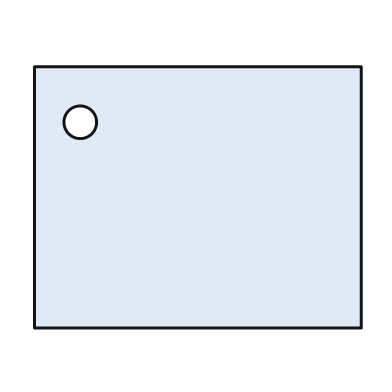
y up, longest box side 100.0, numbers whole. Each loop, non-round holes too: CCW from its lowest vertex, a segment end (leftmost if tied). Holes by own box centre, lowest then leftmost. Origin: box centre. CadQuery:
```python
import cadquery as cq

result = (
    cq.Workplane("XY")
    .moveTo(-50.0, -40.0)
    .lineTo(50.0, -40.0)
    .lineTo(50.0, 40.0)
    .lineTo(-50.0, 40.0)
    .close()
    .moveTo(-36.0, 23.0)
    .circle(5.0)
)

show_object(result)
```